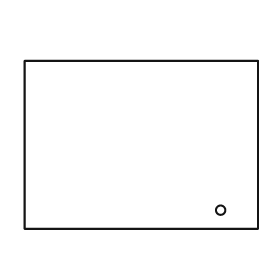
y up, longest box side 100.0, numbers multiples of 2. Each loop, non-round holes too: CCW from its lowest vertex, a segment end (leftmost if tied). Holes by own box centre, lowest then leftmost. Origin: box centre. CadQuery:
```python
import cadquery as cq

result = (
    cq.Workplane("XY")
    .moveTo(-50.0, -36.0)
    .lineTo(50.0, -36.0)
    .lineTo(50.0, 36.0)
    .lineTo(-50.0, 36.0)
    .close()
    .moveTo(34.0, -28.0)
    .circle(2.0)
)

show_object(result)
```